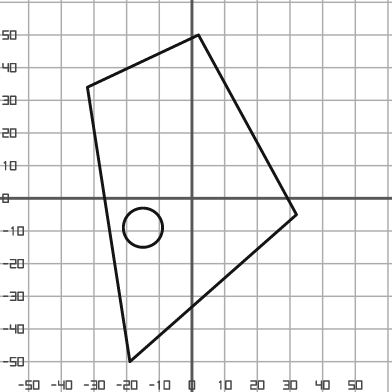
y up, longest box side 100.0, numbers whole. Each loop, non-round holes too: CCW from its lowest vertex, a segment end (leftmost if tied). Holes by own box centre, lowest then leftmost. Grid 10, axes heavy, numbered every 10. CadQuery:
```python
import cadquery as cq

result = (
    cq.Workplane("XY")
    .moveTo(-19.0, -50.0)
    .lineTo(32.0, -5.0)
    .lineTo(2.0, 50.0)
    .lineTo(-32.0, 34.0)
    .close()
    .moveTo(-15.0, -9.0)
    .circle(6.0)
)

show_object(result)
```